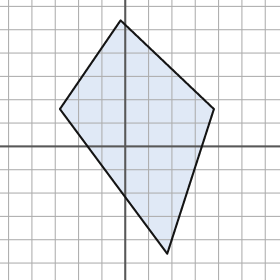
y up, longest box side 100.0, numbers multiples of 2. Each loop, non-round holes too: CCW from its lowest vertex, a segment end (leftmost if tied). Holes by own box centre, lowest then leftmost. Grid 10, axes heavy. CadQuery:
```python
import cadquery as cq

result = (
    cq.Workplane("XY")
    .moveTo(18.0, -46.0)
    .lineTo(38.0, 16.0)
    .lineTo(-2.0, 54.0)
    .lineTo(-28.0, 16.0)
    .close()
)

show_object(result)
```